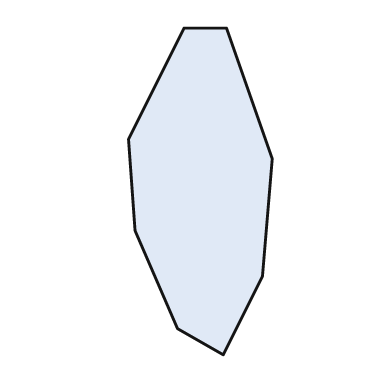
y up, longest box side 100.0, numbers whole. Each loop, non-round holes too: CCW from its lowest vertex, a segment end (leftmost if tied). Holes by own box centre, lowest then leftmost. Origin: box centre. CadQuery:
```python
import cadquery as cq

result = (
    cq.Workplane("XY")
    .moveTo(7.0, -50.0)
    .lineTo(19.0, -26.0)
    .lineTo(22.0, 10.0)
    .lineTo(8.0, 50.0)
    .lineTo(-5.0, 50.0)
    .lineTo(-22.0, 16.0)
    .lineTo(-20.0, -12.0)
    .lineTo(-7.0, -42.0)
    .close()
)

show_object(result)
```